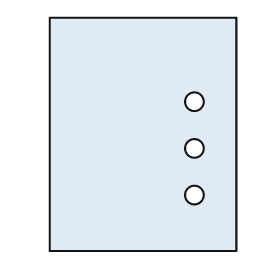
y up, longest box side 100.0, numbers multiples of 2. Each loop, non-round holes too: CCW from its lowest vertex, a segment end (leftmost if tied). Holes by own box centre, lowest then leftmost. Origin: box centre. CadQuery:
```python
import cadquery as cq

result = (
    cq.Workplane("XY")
    .moveTo(-40.0, -50.0)
    .lineTo(40.0, -50.0)
    .lineTo(40.0, 50.0)
    .lineTo(-40.0, 50.0)
    .close()
    .moveTo(22.0, -26.0)
    .circle(4.0)
    .moveTo(22.0, -6.0)
    .circle(4.0)
    .moveTo(22.0, 14.0)
    .circle(4.0)
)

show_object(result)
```